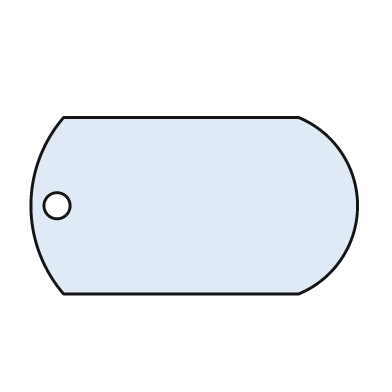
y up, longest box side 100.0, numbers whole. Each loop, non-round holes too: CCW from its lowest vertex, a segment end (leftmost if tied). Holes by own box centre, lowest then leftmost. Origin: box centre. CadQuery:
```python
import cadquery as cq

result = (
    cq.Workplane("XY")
    .moveTo(-40.0, -27.0)
    .lineTo(32.0, -27.0)
    .threePointArc((50.0, 0.0), (32.0, 27.0))
    .lineTo(-40.0, 27.0)
    .threePointArc((-50.0, 0.0), (-40.0, -27.0))
    .close()
    .moveTo(-42.0, 0.0)
    .circle(4.0)
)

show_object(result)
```